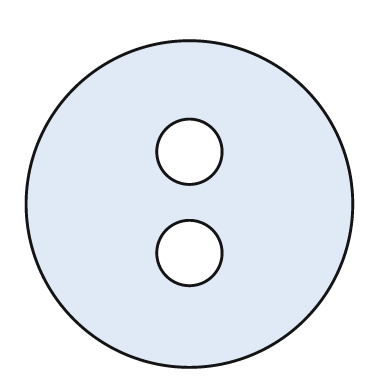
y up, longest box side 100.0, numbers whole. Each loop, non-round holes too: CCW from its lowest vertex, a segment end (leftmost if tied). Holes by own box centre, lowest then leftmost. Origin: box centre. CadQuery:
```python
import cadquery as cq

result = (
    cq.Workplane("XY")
    .moveTo(0.0, 0.0)
    .circle(50.0)
    .moveTo(0.0, -15.0)
    .circle(10.0)
    .moveTo(0.0, 16.0)
    .circle(10.0)
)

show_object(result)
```